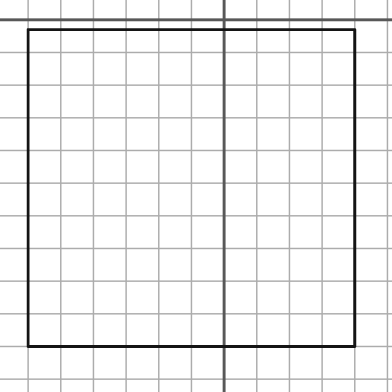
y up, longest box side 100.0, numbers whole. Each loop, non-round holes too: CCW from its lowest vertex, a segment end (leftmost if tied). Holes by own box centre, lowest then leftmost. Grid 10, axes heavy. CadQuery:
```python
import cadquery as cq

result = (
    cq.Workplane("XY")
    .moveTo(-60.0, -100.0)
    .lineTo(40.0, -100.0)
    .lineTo(40.0, -3.0)
    .lineTo(-60.0, -3.0)
    .close()
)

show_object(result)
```